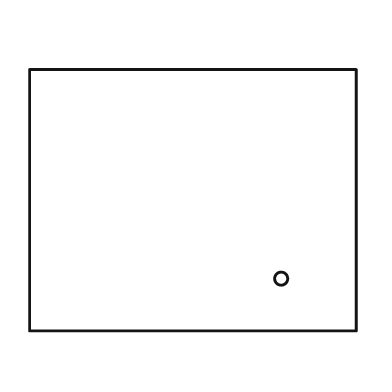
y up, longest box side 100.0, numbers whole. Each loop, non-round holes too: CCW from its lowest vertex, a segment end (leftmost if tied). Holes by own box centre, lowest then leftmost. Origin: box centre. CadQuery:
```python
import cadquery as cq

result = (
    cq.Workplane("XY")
    .moveTo(-50.0, -40.0)
    .lineTo(50.0, -40.0)
    .lineTo(50.0, 40.0)
    .lineTo(-50.0, 40.0)
    .close()
    .moveTo(27.0, -24.0)
    .circle(2.0)
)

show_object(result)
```